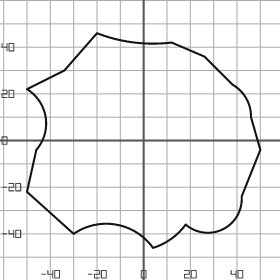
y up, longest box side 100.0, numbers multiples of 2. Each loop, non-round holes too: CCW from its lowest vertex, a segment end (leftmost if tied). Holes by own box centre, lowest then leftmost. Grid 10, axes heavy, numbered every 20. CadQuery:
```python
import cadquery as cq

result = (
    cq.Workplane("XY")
    .moveTo(4.0, -46.0)
    .threePointArc((12.0, -42.0), (18.0, -36.0))
    .threePointArc((34.0, -38.0), (42.0, -24.0))
    .lineTo(50.0, -4.0)
    .lineTo(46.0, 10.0)
    .threePointArc((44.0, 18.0), (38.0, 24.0))
    .lineTo(26.0, 36.0)
    .lineTo(12.0, 42.0)
    .threePointArc((-4.0, 42.0), (-20.0, 46.0))
    .lineTo(-34.0, 30.0)
    .lineTo(-50.0, 22.0)
    .threePointArc((-42.0, 10.0), (-46.0, -4.0))
    .lineTo(-50.0, -22.0)
    .lineTo(-30.0, -40.0)
    .threePointArc((-12.0, -36.0), (4.0, -46.0))
    .close()
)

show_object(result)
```